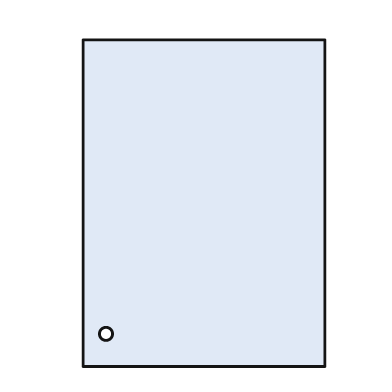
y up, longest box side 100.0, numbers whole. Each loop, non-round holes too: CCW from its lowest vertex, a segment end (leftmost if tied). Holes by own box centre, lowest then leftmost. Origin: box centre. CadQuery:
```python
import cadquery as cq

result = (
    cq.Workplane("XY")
    .moveTo(-37.0, -50.0)
    .lineTo(37.0, -50.0)
    .lineTo(37.0, 50.0)
    .lineTo(-37.0, 50.0)
    .close()
    .moveTo(-30.0, -40.0)
    .circle(2.0)
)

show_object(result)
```